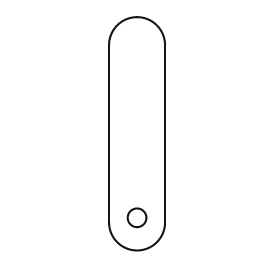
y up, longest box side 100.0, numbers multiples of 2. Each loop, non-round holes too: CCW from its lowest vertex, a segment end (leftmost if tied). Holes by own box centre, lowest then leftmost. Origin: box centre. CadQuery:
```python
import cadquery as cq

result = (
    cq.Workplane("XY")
    .moveTo(-12.0, -38.0)
    .threePointArc((0.0, -50.0), (12.0, -38.0))
    .lineTo(12.0, 38.0)
    .threePointArc((0.0, 50.0), (-12.0, 38.0))
    .close()
    .moveTo(0.0, -36.0)
    .circle(4.0)
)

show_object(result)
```